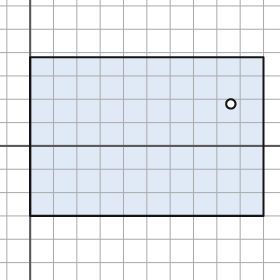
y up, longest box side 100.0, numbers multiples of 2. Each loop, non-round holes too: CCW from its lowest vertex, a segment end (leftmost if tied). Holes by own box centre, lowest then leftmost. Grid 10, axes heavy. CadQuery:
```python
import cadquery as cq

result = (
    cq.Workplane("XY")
    .moveTo(0.0, -30.0)
    .lineTo(100.0, -30.0)
    .lineTo(100.0, 38.0)
    .lineTo(0.0, 38.0)
    .close()
    .moveTo(86.0, 18.0)
    .circle(2.0)
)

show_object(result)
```